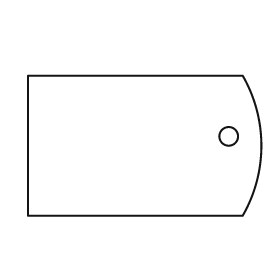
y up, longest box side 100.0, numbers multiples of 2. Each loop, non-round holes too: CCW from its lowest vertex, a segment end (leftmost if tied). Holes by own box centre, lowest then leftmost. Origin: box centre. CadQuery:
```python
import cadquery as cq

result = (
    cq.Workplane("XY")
    .moveTo(-50.0, -30.0)
    .lineTo(42.0, -30.0)
    .threePointArc((50.0, 0.0), (42.0, 30.0))
    .lineTo(-50.0, 30.0)
    .close()
    .moveTo(36.0, 4.0)
    .circle(4.0)
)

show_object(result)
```